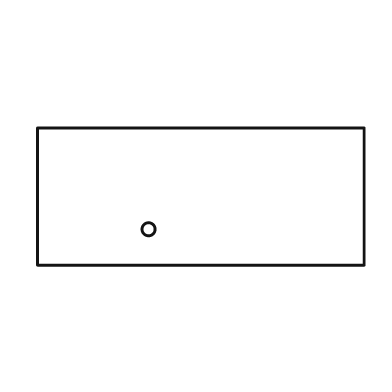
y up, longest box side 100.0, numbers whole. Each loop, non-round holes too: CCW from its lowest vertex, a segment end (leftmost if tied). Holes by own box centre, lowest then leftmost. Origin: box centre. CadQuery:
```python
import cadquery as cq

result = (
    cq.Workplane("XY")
    .moveTo(-50.0, -21.0)
    .lineTo(50.0, -21.0)
    .lineTo(50.0, 21.0)
    .lineTo(-50.0, 21.0)
    .close()
    .moveTo(-16.0, -10.0)
    .circle(2.0)
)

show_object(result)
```